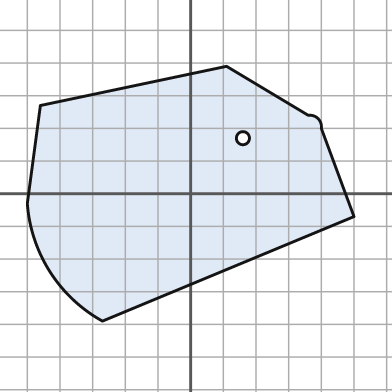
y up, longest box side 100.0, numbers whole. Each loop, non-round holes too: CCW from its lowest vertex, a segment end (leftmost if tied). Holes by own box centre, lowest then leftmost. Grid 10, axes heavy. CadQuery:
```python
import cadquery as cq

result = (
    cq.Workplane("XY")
    .moveTo(-27.0, -39.0)
    .lineTo(50.0, -7.0)
    .lineTo(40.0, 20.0)
    .threePointArc((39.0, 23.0), (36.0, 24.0))
    .lineTo(11.0, 39.0)
    .lineTo(-46.0, 27.0)
    .lineTo(-50.0, -3.0)
    .threePointArc((-43.0, -24.0), (-27.0, -39.0))
    .close()
    .moveTo(16.0, 17.0)
    .circle(2.0)
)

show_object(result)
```